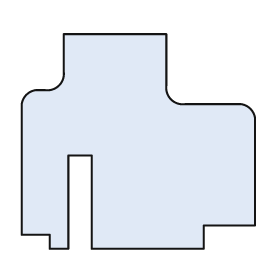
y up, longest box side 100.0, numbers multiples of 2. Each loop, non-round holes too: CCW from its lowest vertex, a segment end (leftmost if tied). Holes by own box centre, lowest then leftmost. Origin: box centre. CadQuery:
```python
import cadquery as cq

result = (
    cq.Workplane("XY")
    .moveTo(-38.0, -46.0)
    .lineTo(-30.0, -46.0)
    .lineTo(-30.0, -6.0)
    .lineTo(-20.0, -6.0)
    .lineTo(-20.0, -46.0)
    .lineTo(28.0, -46.0)
    .lineTo(28.0, -36.0)
    .lineTo(50.0, -36.0)
    .lineTo(50.0, 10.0)
    .threePointArc((48.0, 14.0), (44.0, 16.0))
    .lineTo(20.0, 16.0)
    .threePointArc((14.0, 18.0), (12.0, 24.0))
    .lineTo(12.0, 46.0)
    .lineTo(-32.0, 46.0)
    .lineTo(-32.0, 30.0)
    .threePointArc((-34.0, 24.0), (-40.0, 22.0))
    .lineTo(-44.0, 22.0)
    .threePointArc((-48.0, 20.0), (-50.0, 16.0))
    .lineTo(-50.0, -40.0)
    .lineTo(-38.0, -40.0)
    .close()
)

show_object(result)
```